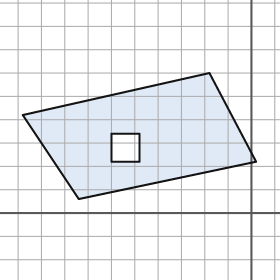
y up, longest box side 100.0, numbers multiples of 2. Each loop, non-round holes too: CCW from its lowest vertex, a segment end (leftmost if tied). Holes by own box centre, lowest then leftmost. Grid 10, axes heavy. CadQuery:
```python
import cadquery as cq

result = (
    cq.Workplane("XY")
    .moveTo(-74.0, 6.0)
    .lineTo(2.0, 22.0)
    .lineTo(-18.0, 60.0)
    .lineTo(-98.0, 42.0)
    .close()
    .moveTo(-60.0, 22.0)
    .lineTo(-48.0, 22.0)
    .lineTo(-48.0, 34.0)
    .lineTo(-60.0, 34.0)
    .close()
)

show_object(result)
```